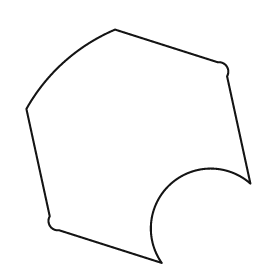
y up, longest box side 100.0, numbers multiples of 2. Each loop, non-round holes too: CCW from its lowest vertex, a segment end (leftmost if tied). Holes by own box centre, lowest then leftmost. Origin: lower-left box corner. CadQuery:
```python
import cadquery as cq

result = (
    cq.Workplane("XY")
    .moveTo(58.0, 0.0)
    .threePointArc((62.0, 34.0), (96.0, 34.0))
    .lineTo(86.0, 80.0)
    .threePointArc((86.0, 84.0), (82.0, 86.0))
    .lineTo(38.0, 100.0)
    .threePointArc((16.0, 86.0), (0.0, 66.0))
    .lineTo(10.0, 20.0)
    .threePointArc((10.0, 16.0), (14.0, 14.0))
    .close()
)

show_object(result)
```